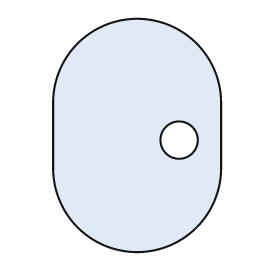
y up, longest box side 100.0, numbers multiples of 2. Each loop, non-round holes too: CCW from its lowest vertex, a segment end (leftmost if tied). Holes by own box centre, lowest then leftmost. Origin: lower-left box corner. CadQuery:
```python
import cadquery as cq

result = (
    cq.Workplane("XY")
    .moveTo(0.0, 36.0)
    .threePointArc((36.0, 0.0), (72.0, 36.0))
    .lineTo(72.0, 64.0)
    .threePointArc((36.0, 100.0), (0.0, 64.0))
    .close()
    .moveTo(54.0, 48.0)
    .circle(8.0)
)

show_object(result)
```